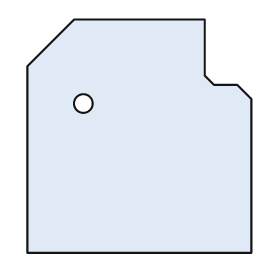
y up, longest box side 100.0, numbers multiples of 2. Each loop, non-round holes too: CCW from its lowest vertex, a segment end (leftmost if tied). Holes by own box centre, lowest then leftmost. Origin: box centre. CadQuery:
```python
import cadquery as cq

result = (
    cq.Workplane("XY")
    .moveTo(-48.0, -50.0)
    .lineTo(48.0, -50.0)
    .lineTo(48.0, 16.0)
    .lineTo(42.0, 22.0)
    .lineTo(32.0, 22.0)
    .lineTo(28.0, 26.0)
    .lineTo(28.0, 50.0)
    .lineTo(-28.0, 50.0)
    .lineTo(-48.0, 30.0)
    .close()
    .moveTo(-24.0, 14.0)
    .circle(4.0)
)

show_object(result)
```